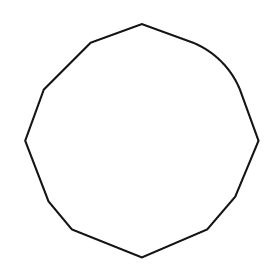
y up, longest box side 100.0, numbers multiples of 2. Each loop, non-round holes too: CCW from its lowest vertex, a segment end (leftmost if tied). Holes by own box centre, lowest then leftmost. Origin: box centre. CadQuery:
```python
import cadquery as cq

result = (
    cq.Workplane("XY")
    .moveTo(0.0, -50.0)
    .lineTo(28.0, -38.0)
    .lineTo(40.0, -24.0)
    .lineTo(50.0, 0.0)
    .lineTo(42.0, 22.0)
    .threePointArc((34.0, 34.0), (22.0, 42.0))
    .lineTo(0.0, 50.0)
    .lineTo(-22.0, 42.0)
    .lineTo(-42.0, 22.0)
    .lineTo(-50.0, 0.0)
    .lineTo(-40.0, -26.0)
    .lineTo(-30.0, -38.0)
    .close()
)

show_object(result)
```